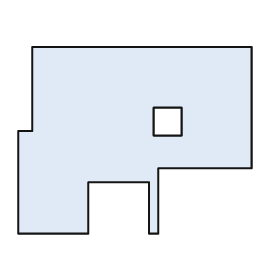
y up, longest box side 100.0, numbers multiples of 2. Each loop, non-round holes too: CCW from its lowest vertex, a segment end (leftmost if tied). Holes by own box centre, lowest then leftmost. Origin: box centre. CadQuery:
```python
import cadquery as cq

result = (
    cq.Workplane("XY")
    .moveTo(-50.0, -40.0)
    .lineTo(-20.0, -40.0)
    .lineTo(-20.0, -18.0)
    .lineTo(6.0, -18.0)
    .lineTo(6.0, -40.0)
    .lineTo(10.0, -40.0)
    .lineTo(10.0, -12.0)
    .lineTo(50.0, -12.0)
    .lineTo(50.0, 40.0)
    .lineTo(-44.0, 40.0)
    .lineTo(-44.0, 4.0)
    .lineTo(-50.0, 4.0)
    .close()
    .moveTo(8.0, 2.0)
    .lineTo(20.0, 2.0)
    .lineTo(20.0, 14.0)
    .lineTo(8.0, 14.0)
    .close()
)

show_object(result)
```